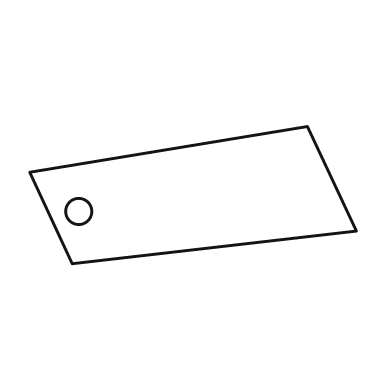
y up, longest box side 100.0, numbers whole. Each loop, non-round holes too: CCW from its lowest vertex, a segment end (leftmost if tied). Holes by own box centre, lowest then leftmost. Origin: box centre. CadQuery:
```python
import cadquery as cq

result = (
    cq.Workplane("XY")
    .moveTo(-37.0, -21.0)
    .lineTo(50.0, -11.0)
    .lineTo(35.0, 21.0)
    .lineTo(-50.0, 7.0)
    .close()
    .moveTo(-35.0, -5.0)
    .circle(4.0)
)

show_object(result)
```